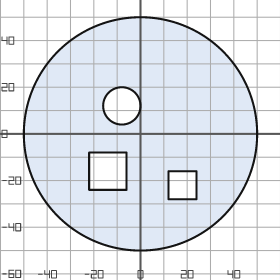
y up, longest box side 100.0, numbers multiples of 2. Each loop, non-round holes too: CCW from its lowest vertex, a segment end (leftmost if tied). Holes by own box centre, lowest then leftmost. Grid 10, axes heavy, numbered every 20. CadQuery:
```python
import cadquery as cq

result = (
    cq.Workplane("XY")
    .moveTo(0.0, 0.0)
    .circle(50.0)
    .moveTo(12.0, -28.0)
    .lineTo(24.0, -28.0)
    .lineTo(24.0, -16.0)
    .lineTo(12.0, -16.0)
    .close()
    .moveTo(-22.0, -24.0)
    .lineTo(-6.0, -24.0)
    .lineTo(-6.0, -8.0)
    .lineTo(-22.0, -8.0)
    .close()
    .moveTo(-8.0, 12.0)
    .circle(8.0)
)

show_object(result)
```